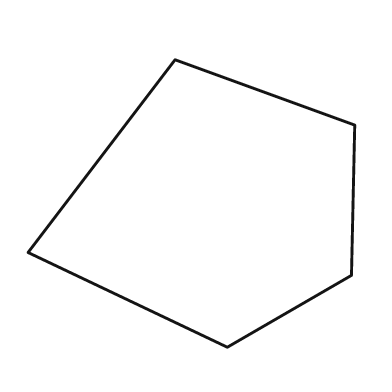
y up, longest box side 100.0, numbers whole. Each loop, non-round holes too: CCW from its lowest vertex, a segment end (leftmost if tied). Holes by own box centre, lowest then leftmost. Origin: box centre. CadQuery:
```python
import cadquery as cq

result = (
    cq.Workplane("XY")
    .moveTo(11.0, -44.0)
    .lineTo(49.0, -22.0)
    .lineTo(50.0, 24.0)
    .lineTo(-5.0, 44.0)
    .lineTo(-50.0, -15.0)
    .close()
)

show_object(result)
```